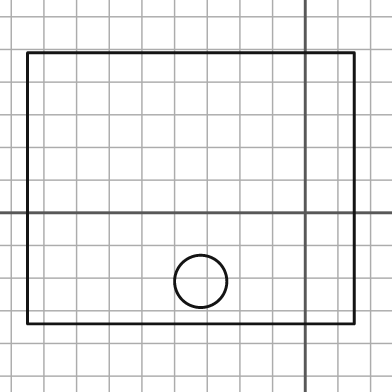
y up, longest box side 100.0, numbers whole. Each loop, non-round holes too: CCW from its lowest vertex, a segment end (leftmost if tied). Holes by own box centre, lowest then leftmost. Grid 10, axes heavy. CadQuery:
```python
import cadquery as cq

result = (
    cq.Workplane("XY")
    .moveTo(-85.0, -34.0)
    .lineTo(15.0, -34.0)
    .lineTo(15.0, 49.0)
    .lineTo(-85.0, 49.0)
    .close()
    .moveTo(-32.0, -21.0)
    .circle(8.0)
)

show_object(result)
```